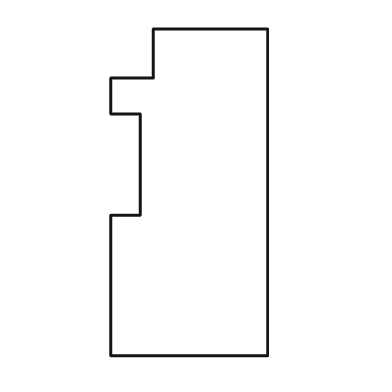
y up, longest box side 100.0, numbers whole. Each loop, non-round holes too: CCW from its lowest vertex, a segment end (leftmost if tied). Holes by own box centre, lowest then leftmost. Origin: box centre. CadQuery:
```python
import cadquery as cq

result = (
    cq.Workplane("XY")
    .moveTo(-24.0, -50.0)
    .lineTo(24.0, -50.0)
    .lineTo(24.0, 50.0)
    .lineTo(-11.0, 50.0)
    .lineTo(-11.0, 35.0)
    .lineTo(-24.0, 35.0)
    .lineTo(-24.0, 24.0)
    .lineTo(-15.0, 24.0)
    .lineTo(-15.0, -7.0)
    .lineTo(-24.0, -7.0)
    .close()
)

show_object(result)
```